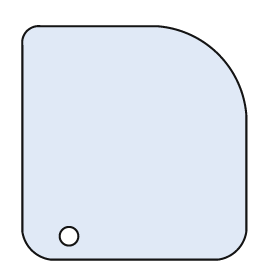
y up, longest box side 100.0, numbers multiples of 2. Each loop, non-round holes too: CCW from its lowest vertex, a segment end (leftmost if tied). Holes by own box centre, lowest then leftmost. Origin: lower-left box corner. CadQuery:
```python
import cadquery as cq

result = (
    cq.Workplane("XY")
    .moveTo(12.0, 0.0)
    .lineTo(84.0, 0.0)
    .threePointArc((92.0, 4.0), (96.0, 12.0))
    .lineTo(96.0, 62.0)
    .threePointArc((84.0, 88.0), (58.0, 100.0))
    .lineTo(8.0, 100.0)
    .threePointArc((2.0, 98.0), (0.0, 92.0))
    .lineTo(0.0, 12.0)
    .threePointArc((4.0, 4.0), (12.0, 0.0))
    .close()
    .moveTo(20.0, 10.0)
    .circle(4.0)
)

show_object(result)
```